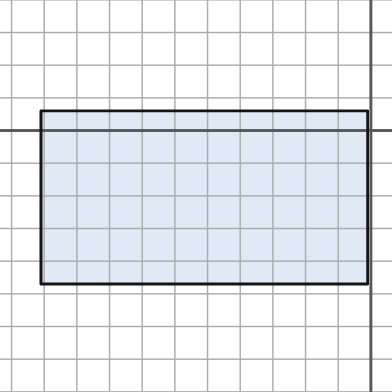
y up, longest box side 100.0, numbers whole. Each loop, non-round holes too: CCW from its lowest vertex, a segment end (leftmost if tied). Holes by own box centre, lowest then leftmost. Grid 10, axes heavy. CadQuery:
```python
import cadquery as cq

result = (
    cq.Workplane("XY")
    .moveTo(-101.0, -47.0)
    .lineTo(-1.0, -47.0)
    .lineTo(-1.0, 6.0)
    .lineTo(-101.0, 6.0)
    .close()
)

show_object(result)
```